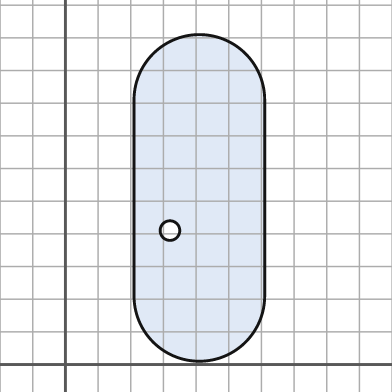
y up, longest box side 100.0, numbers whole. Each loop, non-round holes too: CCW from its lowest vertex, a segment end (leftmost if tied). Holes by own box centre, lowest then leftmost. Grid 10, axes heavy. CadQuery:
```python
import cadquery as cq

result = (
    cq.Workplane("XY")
    .moveTo(21.0, 21.0)
    .threePointArc((41.0, 1.0), (61.0, 21.0))
    .lineTo(61.0, 81.0)
    .threePointArc((41.0, 101.0), (21.0, 81.0))
    .close()
    .moveTo(32.0, 41.0)
    .circle(3.0)
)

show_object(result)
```